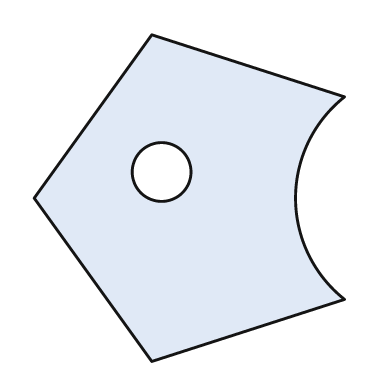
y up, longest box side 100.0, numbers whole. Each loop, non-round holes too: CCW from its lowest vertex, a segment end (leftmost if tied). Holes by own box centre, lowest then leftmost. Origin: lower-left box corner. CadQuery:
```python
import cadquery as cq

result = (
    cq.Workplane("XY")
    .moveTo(36.0, 0.0)
    .lineTo(95.0, 19.0)
    .threePointArc((80.0, 50.0), (95.0, 81.0))
    .lineTo(36.0, 100.0)
    .lineTo(0.0, 50.0)
    .close()
    .moveTo(39.0, 58.0)
    .circle(9.0)
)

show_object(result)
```